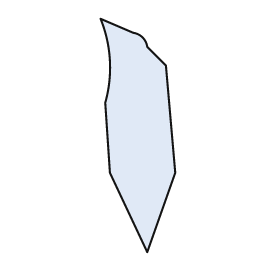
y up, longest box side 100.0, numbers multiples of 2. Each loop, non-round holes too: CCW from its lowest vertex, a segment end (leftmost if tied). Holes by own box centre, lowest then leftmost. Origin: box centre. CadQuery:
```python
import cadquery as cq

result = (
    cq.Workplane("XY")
    .moveTo(4.0, -50.0)
    .lineTo(16.0, -16.0)
    .lineTo(12.0, 30.0)
    .lineTo(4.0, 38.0)
    .threePointArc((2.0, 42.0), (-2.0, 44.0))
    .lineTo(-16.0, 50.0)
    .threePointArc((-12.0, 32.0), (-14.0, 14.0))
    .lineTo(-12.0, -16.0)
    .close()
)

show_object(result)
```